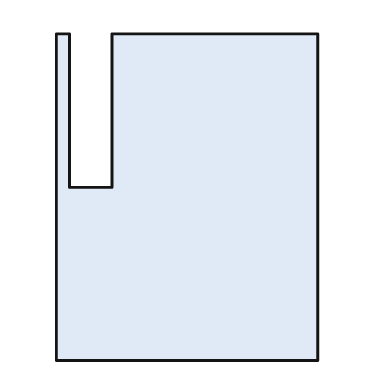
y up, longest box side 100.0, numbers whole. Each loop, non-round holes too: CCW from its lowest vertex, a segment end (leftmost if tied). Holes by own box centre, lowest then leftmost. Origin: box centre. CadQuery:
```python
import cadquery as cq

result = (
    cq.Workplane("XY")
    .moveTo(-40.0, -50.0)
    .lineTo(40.0, -50.0)
    .lineTo(40.0, 50.0)
    .lineTo(-23.0, 50.0)
    .lineTo(-23.0, 3.0)
    .lineTo(-36.0, 3.0)
    .lineTo(-36.0, 50.0)
    .lineTo(-40.0, 50.0)
    .close()
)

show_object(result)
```